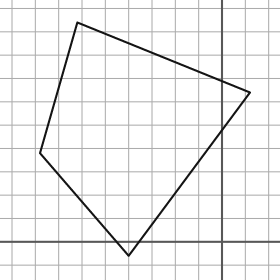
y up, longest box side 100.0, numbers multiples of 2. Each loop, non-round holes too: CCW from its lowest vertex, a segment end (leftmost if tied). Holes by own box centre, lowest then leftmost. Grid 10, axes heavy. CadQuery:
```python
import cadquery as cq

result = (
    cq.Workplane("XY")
    .moveTo(-40.0, -6.0)
    .lineTo(12.0, 64.0)
    .lineTo(-62.0, 94.0)
    .lineTo(-78.0, 38.0)
    .close()
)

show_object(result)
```